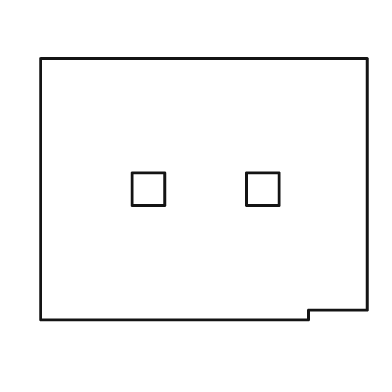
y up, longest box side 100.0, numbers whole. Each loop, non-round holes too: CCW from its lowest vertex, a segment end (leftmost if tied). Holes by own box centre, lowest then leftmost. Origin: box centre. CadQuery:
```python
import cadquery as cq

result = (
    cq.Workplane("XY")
    .moveTo(-50.0, -40.0)
    .lineTo(32.0, -40.0)
    .lineTo(32.0, -37.0)
    .lineTo(50.0, -37.0)
    .lineTo(50.0, 40.0)
    .lineTo(-50.0, 40.0)
    .close()
    .moveTo(-22.0, -5.0)
    .lineTo(-12.0, -5.0)
    .lineTo(-12.0, 5.0)
    .lineTo(-22.0, 5.0)
    .close()
    .moveTo(13.0, -5.0)
    .lineTo(23.0, -5.0)
    .lineTo(23.0, 5.0)
    .lineTo(13.0, 5.0)
    .close()
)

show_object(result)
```